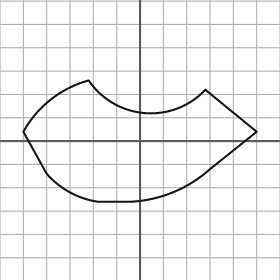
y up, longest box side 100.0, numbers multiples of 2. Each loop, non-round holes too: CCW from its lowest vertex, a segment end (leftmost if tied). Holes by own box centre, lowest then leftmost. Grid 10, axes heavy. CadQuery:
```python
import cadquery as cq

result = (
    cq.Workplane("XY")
    .moveTo(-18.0, -26.0)
    .lineTo(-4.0, -26.0)
    .threePointArc((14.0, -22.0), (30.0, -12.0))
    .lineTo(50.0, 4.0)
    .lineTo(28.0, 22.0)
    .threePointArc((2.0, 12.0), (-22.0, 26.0))
    .threePointArc((-38.0, 18.0), (-50.0, 4.0))
    .lineTo(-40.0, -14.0)
    .threePointArc((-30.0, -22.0), (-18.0, -26.0))
    .close()
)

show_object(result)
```